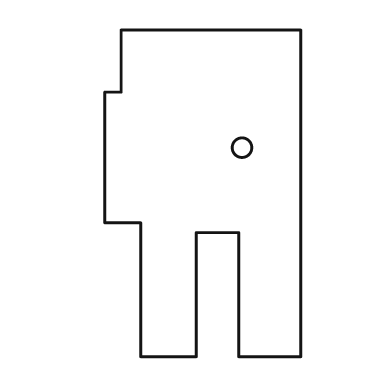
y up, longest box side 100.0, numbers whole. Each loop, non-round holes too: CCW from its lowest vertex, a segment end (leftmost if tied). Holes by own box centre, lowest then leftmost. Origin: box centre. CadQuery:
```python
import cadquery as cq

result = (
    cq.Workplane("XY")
    .moveTo(-19.0, -50.0)
    .lineTo(-2.0, -50.0)
    .lineTo(-2.0, -12.0)
    .lineTo(11.0, -12.0)
    .lineTo(11.0, -50.0)
    .lineTo(30.0, -50.0)
    .lineTo(30.0, 50.0)
    .lineTo(-25.0, 50.0)
    .lineTo(-25.0, 31.0)
    .lineTo(-30.0, 31.0)
    .lineTo(-30.0, -9.0)
    .lineTo(-19.0, -9.0)
    .close()
    .moveTo(12.0, 14.0)
    .circle(3.0)
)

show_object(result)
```